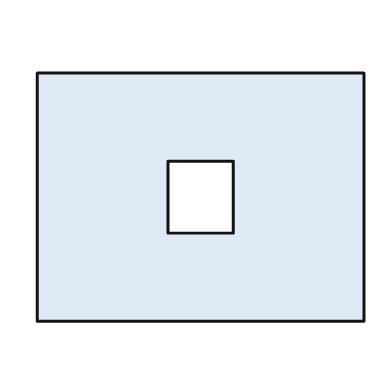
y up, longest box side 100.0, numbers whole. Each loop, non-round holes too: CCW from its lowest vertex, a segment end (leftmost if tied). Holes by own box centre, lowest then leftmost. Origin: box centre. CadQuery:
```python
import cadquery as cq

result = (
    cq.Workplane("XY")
    .moveTo(-50.0, -38.0)
    .lineTo(50.0, -38.0)
    .lineTo(50.0, 38.0)
    .lineTo(-50.0, 38.0)
    .close()
    .moveTo(-10.0, -11.0)
    .lineTo(10.0, -11.0)
    .lineTo(10.0, 11.0)
    .lineTo(-10.0, 11.0)
    .close()
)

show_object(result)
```